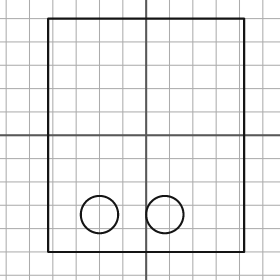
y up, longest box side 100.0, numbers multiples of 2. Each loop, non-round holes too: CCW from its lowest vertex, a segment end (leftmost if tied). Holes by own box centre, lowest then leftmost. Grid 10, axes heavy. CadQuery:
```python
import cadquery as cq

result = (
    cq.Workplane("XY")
    .moveTo(-42.0, -50.0)
    .lineTo(42.0, -50.0)
    .lineTo(42.0, 50.0)
    .lineTo(-42.0, 50.0)
    .close()
    .moveTo(-20.0, -34.0)
    .circle(8.0)
    .moveTo(8.0, -34.0)
    .circle(8.0)
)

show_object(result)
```